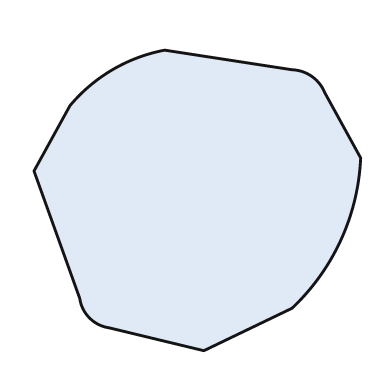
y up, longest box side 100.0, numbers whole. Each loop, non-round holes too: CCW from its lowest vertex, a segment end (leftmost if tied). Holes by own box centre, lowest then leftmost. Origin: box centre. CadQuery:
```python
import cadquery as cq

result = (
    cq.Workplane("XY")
    .moveTo(2.0, -46.0)
    .lineTo(29.0, -33.0)
    .threePointArc((44.0, -12.0), (50.0, 13.0))
    .lineTo(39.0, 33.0)
    .threePointArc((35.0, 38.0), (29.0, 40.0))
    .lineTo(-10.0, 46.0)
    .threePointArc((-26.0, 40.0), (-39.0, 29.0))
    .lineTo(-50.0, 9.0)
    .lineTo(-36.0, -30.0)
    .threePointArc((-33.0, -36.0), (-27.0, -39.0))
    .close()
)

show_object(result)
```